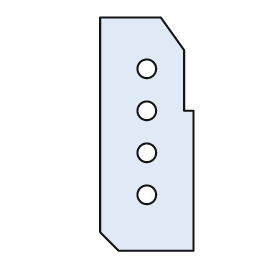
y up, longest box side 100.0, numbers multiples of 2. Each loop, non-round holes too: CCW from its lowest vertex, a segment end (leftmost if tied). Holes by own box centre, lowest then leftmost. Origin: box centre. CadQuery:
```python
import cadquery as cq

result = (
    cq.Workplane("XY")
    .moveTo(-12.0, -50.0)
    .lineTo(20.0, -50.0)
    .lineTo(20.0, 10.0)
    .lineTo(16.0, 10.0)
    .lineTo(16.0, 36.0)
    .lineTo(6.0, 50.0)
    .lineTo(-20.0, 50.0)
    .lineTo(-20.0, -42.0)
    .close()
    .moveTo(0.0, -26.0)
    .circle(4.0)
    .moveTo(0.0, -8.0)
    .circle(4.0)
    .moveTo(0.0, 10.0)
    .circle(4.0)
    .moveTo(0.0, 28.0)
    .circle(4.0)
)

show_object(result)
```